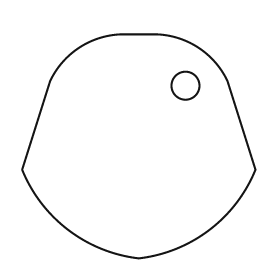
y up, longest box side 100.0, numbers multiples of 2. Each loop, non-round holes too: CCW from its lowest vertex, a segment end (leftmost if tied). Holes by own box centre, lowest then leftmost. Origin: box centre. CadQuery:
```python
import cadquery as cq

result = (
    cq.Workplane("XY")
    .moveTo(0.0, -48.0)
    .threePointArc((30.0, -36.0), (50.0, -10.0))
    .lineTo(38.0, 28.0)
    .threePointArc((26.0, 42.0), (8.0, 48.0))
    .lineTo(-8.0, 48.0)
    .threePointArc((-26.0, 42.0), (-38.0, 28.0))
    .lineTo(-50.0, -10.0)
    .threePointArc((-30.0, -36.0), (0.0, -48.0))
    .close()
    .moveTo(20.0, 26.0)
    .circle(6.0)
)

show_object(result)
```